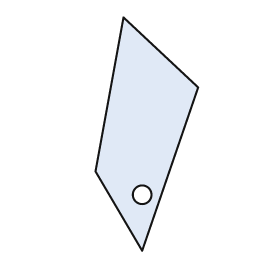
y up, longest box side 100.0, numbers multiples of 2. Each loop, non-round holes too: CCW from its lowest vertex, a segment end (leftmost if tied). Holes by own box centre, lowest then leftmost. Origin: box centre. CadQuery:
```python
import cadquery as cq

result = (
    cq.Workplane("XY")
    .moveTo(-2.0, -50.0)
    .lineTo(22.0, 20.0)
    .lineTo(-10.0, 50.0)
    .lineTo(-22.0, -16.0)
    .close()
    .moveTo(-2.0, -26.0)
    .circle(4.0)
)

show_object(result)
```